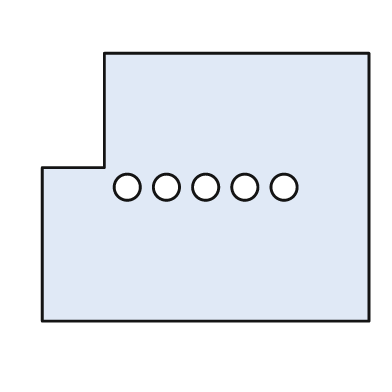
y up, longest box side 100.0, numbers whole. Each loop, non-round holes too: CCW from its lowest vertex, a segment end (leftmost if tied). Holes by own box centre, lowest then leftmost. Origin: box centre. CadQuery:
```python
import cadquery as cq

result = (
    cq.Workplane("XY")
    .moveTo(-50.0, -41.0)
    .lineTo(50.0, -41.0)
    .lineTo(50.0, 41.0)
    .lineTo(-31.0, 41.0)
    .lineTo(-31.0, 6.0)
    .lineTo(-50.0, 6.0)
    .close()
    .moveTo(-24.0, 0.0)
    .circle(4.0)
    .moveTo(-12.0, 0.0)
    .circle(4.0)
    .moveTo(0.0, 0.0)
    .circle(4.0)
    .moveTo(12.0, 0.0)
    .circle(4.0)
    .moveTo(24.0, 0.0)
    .circle(4.0)
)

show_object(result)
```